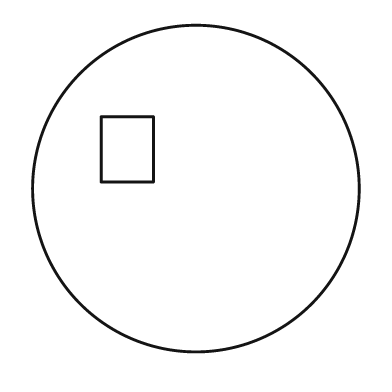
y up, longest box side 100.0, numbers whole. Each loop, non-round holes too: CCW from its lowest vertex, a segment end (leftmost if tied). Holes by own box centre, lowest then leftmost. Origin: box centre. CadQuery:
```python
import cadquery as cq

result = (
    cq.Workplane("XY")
    .moveTo(0.0, 0.0)
    .circle(50.0)
    .moveTo(-29.0, 2.0)
    .lineTo(-13.0, 2.0)
    .lineTo(-13.0, 22.0)
    .lineTo(-29.0, 22.0)
    .close()
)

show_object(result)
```